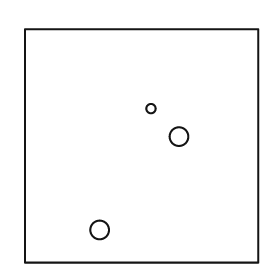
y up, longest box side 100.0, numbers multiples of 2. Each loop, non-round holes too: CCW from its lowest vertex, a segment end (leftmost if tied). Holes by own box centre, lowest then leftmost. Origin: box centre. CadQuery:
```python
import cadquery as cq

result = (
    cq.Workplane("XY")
    .moveTo(-50.0, -50.0)
    .lineTo(50.0, -50.0)
    .lineTo(50.0, 50.0)
    .lineTo(-50.0, 50.0)
    .close()
    .moveTo(-18.0, -36.0)
    .circle(4.0)
    .moveTo(16.0, 4.0)
    .circle(4.0)
    .moveTo(4.0, 16.0)
    .circle(2.0)
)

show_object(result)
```